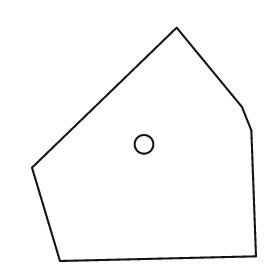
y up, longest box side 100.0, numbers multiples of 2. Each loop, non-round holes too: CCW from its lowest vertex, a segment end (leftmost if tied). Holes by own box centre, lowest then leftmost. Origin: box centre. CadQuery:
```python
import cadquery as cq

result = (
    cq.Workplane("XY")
    .moveTo(-36.0, -50.0)
    .lineTo(48.0, -48.0)
    .lineTo(46.0, 6.0)
    .lineTo(42.0, 16.0)
    .lineTo(14.0, 50.0)
    .lineTo(-48.0, -10.0)
    .close()
    .moveTo(0.0, 0.0)
    .circle(4.0)
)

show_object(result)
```